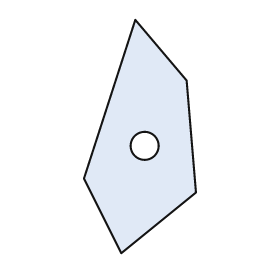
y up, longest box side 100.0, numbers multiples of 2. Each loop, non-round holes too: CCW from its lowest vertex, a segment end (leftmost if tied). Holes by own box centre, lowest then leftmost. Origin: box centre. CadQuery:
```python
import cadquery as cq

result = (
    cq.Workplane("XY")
    .moveTo(-8.0, -50.0)
    .lineTo(24.0, -24.0)
    .lineTo(20.0, 24.0)
    .lineTo(-2.0, 50.0)
    .lineTo(-24.0, -18.0)
    .close()
    .moveTo(2.0, -4.0)
    .circle(6.0)
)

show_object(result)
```